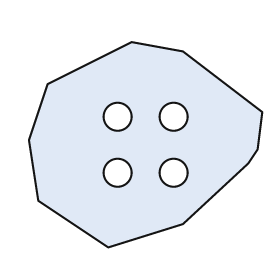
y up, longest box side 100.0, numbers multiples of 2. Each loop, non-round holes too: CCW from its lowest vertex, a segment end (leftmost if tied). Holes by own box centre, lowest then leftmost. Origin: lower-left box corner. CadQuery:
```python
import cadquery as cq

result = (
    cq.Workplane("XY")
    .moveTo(34.0, 0.0)
    .lineTo(66.0, 10.0)
    .lineTo(94.0, 36.0)
    .lineTo(98.0, 42.0)
    .lineTo(100.0, 58.0)
    .lineTo(66.0, 84.0)
    .lineTo(44.0, 88.0)
    .lineTo(8.0, 70.0)
    .lineTo(0.0, 46.0)
    .lineTo(4.0, 20.0)
    .close()
    .moveTo(38.0, 32.0)
    .circle(6.0)
    .moveTo(62.0, 32.0)
    .circle(6.0)
    .moveTo(38.0, 56.0)
    .circle(6.0)
    .moveTo(62.0, 56.0)
    .circle(6.0)
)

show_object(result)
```